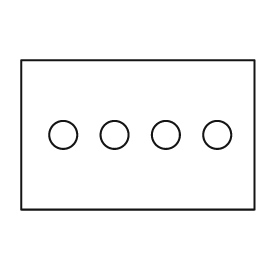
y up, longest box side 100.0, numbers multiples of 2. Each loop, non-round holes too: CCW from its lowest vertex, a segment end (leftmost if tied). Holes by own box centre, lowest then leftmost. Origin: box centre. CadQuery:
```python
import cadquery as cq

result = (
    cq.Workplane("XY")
    .moveTo(-50.0, -32.0)
    .lineTo(50.0, -32.0)
    .lineTo(50.0, 32.0)
    .lineTo(-50.0, 32.0)
    .close()
    .moveTo(-32.0, 0.0)
    .circle(6.0)
    .moveTo(-10.0, 0.0)
    .circle(6.0)
    .moveTo(12.0, 0.0)
    .circle(6.0)
    .moveTo(34.0, 0.0)
    .circle(6.0)
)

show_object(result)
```